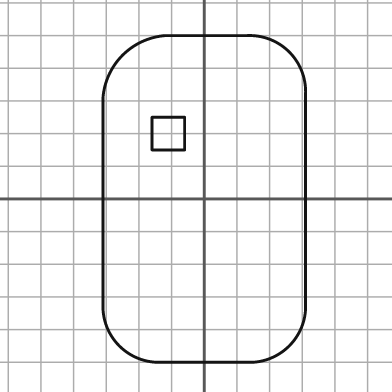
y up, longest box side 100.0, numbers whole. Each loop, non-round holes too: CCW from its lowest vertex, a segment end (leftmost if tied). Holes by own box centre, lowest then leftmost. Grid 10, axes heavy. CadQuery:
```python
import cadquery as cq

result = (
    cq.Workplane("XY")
    .moveTo(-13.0, -50.0)
    .lineTo(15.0, -50.0)
    .threePointArc((26.0, -45.0), (31.0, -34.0))
    .lineTo(31.0, 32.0)
    .threePointArc((26.0, 45.0), (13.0, 50.0))
    .lineTo(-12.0, 50.0)
    .threePointArc((-25.0, 44.0), (-31.0, 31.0))
    .lineTo(-31.0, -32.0)
    .threePointArc((-26.0, -45.0), (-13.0, -50.0))
    .close()
    .moveTo(-16.0, 15.0)
    .lineTo(-6.0, 15.0)
    .lineTo(-6.0, 25.0)
    .lineTo(-16.0, 25.0)
    .close()
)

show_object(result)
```